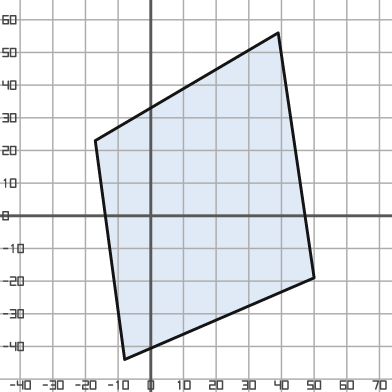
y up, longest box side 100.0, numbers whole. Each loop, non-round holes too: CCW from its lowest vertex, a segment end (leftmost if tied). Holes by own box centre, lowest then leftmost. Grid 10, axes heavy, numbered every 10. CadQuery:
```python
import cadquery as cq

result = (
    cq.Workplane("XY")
    .moveTo(-8.0, -44.0)
    .lineTo(50.0, -19.0)
    .lineTo(39.0, 56.0)
    .lineTo(-17.0, 23.0)
    .close()
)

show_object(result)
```